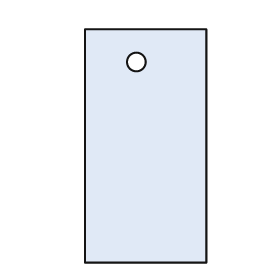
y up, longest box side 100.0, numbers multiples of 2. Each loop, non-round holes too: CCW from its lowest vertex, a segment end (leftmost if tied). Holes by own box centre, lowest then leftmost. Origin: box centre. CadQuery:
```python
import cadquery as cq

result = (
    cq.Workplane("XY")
    .moveTo(-26.0, -50.0)
    .lineTo(26.0, -50.0)
    .lineTo(26.0, 50.0)
    .lineTo(-26.0, 50.0)
    .close()
    .moveTo(-4.0, 36.0)
    .circle(4.0)
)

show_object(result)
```